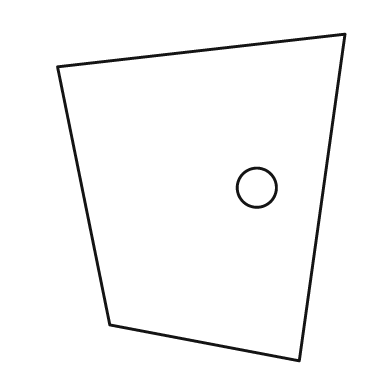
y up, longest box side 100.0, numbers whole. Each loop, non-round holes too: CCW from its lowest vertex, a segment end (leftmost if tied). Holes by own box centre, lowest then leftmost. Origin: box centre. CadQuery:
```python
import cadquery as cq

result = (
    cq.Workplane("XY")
    .moveTo(30.0, -50.0)
    .lineTo(44.0, 50.0)
    .lineTo(-44.0, 40.0)
    .lineTo(-28.0, -39.0)
    .close()
    .moveTo(17.0, 3.0)
    .circle(6.0)
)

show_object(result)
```